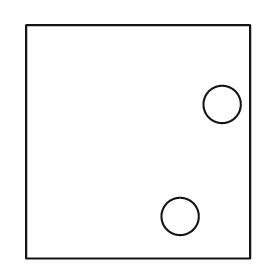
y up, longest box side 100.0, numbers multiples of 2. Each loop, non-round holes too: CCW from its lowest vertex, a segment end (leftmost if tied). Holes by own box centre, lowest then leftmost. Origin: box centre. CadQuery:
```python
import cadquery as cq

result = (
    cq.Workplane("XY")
    .moveTo(-48.0, -50.0)
    .lineTo(48.0, -50.0)
    .lineTo(48.0, 50.0)
    .lineTo(-48.0, 50.0)
    .close()
    .moveTo(18.0, -32.0)
    .circle(8.0)
    .moveTo(36.0, 16.0)
    .circle(8.0)
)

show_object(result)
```